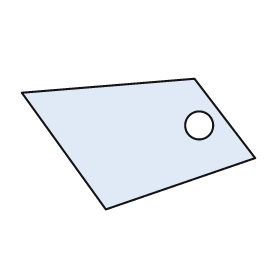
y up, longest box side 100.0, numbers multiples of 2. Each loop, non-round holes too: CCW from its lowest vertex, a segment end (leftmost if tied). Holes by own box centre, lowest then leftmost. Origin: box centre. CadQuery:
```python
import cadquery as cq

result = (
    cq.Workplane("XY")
    .moveTo(-14.0, -28.0)
    .lineTo(50.0, -6.0)
    .lineTo(24.0, 28.0)
    .lineTo(-50.0, 22.0)
    .close()
    .moveTo(26.0, 8.0)
    .circle(6.0)
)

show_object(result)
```